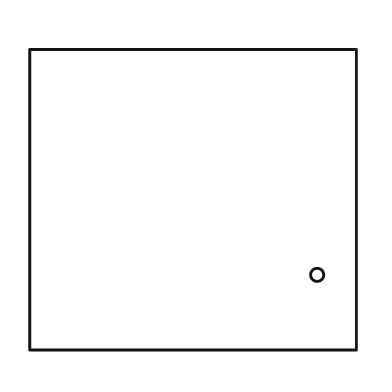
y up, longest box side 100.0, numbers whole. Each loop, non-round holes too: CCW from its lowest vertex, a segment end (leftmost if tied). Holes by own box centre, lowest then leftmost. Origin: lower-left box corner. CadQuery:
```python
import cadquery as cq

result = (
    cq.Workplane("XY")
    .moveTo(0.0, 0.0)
    .lineTo(100.0, 0.0)
    .lineTo(100.0, 92.0)
    .lineTo(0.0, 92.0)
    .close()
    .moveTo(88.0, 23.0)
    .circle(2.0)
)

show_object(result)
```